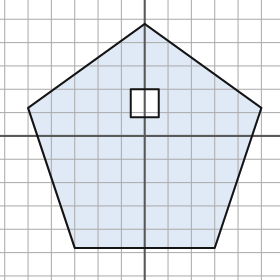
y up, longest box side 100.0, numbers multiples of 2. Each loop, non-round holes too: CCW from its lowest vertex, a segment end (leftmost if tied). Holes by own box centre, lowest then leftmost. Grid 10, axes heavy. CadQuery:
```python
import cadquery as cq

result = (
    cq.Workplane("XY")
    .moveTo(-30.0, -48.0)
    .lineTo(30.0, -48.0)
    .lineTo(50.0, 12.0)
    .lineTo(0.0, 48.0)
    .lineTo(-50.0, 12.0)
    .close()
    .moveTo(-6.0, 8.0)
    .lineTo(6.0, 8.0)
    .lineTo(6.0, 20.0)
    .lineTo(-6.0, 20.0)
    .close()
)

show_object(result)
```